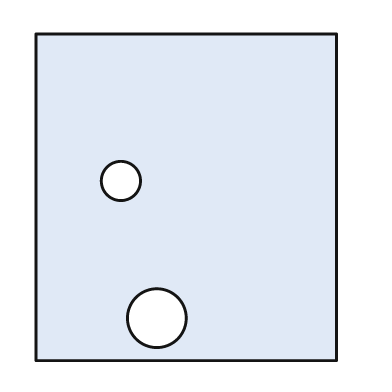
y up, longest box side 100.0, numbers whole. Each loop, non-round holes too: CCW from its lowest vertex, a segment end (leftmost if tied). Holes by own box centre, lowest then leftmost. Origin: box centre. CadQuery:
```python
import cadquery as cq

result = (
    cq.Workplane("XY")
    .moveTo(-46.0, -50.0)
    .lineTo(46.0, -50.0)
    .lineTo(46.0, 50.0)
    .lineTo(-46.0, 50.0)
    .close()
    .moveTo(-9.0, -37.0)
    .circle(9.0)
    .moveTo(-20.0, 5.0)
    .circle(6.0)
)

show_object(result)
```